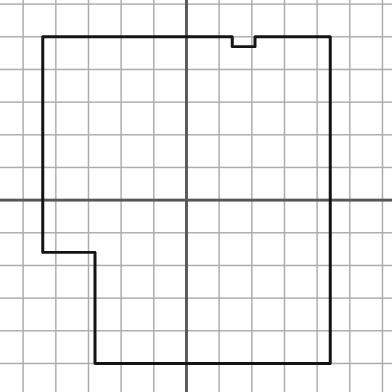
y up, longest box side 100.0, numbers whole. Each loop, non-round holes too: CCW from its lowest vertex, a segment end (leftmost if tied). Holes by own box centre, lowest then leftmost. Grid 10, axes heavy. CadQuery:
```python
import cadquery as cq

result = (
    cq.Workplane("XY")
    .moveTo(-28.0, -50.0)
    .lineTo(44.0, -50.0)
    .lineTo(44.0, 50.0)
    .lineTo(21.0, 50.0)
    .lineTo(21.0, 47.0)
    .lineTo(14.0, 47.0)
    .lineTo(14.0, 50.0)
    .lineTo(-44.0, 50.0)
    .lineTo(-44.0, -16.0)
    .lineTo(-28.0, -16.0)
    .close()
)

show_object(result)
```